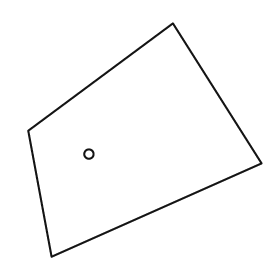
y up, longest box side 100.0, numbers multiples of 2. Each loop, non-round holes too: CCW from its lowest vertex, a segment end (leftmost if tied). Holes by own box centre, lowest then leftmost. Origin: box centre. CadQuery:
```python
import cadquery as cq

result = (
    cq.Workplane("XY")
    .moveTo(-40.0, -50.0)
    .lineTo(50.0, -10.0)
    .lineTo(12.0, 50.0)
    .lineTo(-50.0, 4.0)
    .close()
    .moveTo(-24.0, -6.0)
    .circle(2.0)
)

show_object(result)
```